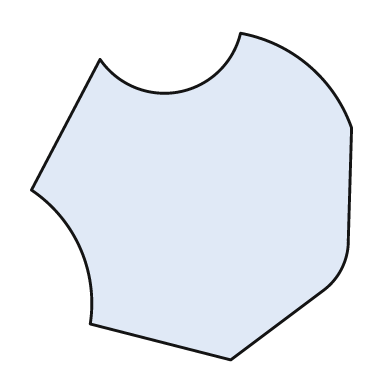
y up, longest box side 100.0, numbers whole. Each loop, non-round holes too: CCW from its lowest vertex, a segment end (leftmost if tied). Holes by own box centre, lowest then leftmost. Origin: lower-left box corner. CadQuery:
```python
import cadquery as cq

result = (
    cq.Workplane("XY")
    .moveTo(61.0, 0.0)
    .lineTo(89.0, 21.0)
    .threePointArc((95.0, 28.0), (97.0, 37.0))
    .lineTo(98.0, 71.0)
    .threePointArc((85.0, 90.0), (64.0, 100.0))
    .threePointArc((45.0, 82.0), (21.0, 92.0))
    .lineTo(0.0, 52.0)
    .threePointArc((15.0, 34.0), (18.0, 11.0))
    .close()
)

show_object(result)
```